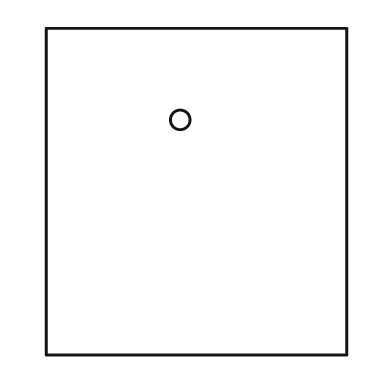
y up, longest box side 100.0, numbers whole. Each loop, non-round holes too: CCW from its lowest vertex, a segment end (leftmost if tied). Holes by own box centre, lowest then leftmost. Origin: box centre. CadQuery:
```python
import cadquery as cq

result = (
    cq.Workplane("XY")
    .moveTo(-46.0, -50.0)
    .lineTo(46.0, -50.0)
    .lineTo(46.0, 50.0)
    .lineTo(-46.0, 50.0)
    .close()
    .moveTo(-5.0, 22.0)
    .circle(3.0)
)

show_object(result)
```